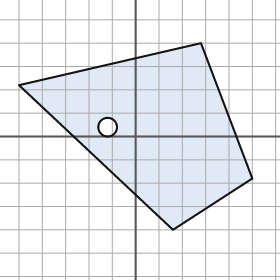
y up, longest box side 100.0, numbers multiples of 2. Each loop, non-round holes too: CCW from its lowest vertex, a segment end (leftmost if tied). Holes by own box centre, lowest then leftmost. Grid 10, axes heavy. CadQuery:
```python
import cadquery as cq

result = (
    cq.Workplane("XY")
    .moveTo(16.0, -40.0)
    .lineTo(50.0, -18.0)
    .lineTo(28.0, 40.0)
    .lineTo(-50.0, 22.0)
    .close()
    .moveTo(-12.0, 4.0)
    .circle(4.0)
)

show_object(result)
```